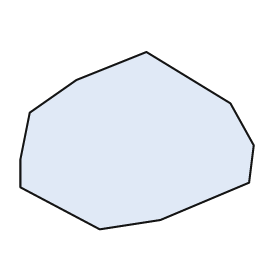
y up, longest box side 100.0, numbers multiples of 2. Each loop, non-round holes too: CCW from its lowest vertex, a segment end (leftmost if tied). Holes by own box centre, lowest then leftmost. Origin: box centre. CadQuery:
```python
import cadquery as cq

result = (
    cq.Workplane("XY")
    .moveTo(-16.0, -38.0)
    .lineTo(10.0, -34.0)
    .lineTo(48.0, -18.0)
    .lineTo(50.0, -2.0)
    .lineTo(40.0, 16.0)
    .lineTo(4.0, 38.0)
    .lineTo(-26.0, 26.0)
    .lineTo(-46.0, 12.0)
    .lineTo(-50.0, -8.0)
    .lineTo(-50.0, -20.0)
    .close()
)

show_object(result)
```